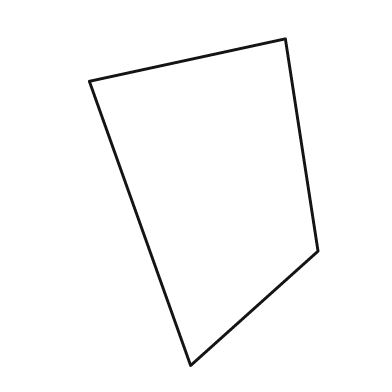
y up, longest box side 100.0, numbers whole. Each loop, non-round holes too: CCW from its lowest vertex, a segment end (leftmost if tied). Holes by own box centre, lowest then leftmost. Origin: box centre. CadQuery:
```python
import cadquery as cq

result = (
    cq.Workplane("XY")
    .moveTo(-4.0, -50.0)
    .lineTo(35.0, -15.0)
    .lineTo(25.0, 50.0)
    .lineTo(-35.0, 37.0)
    .close()
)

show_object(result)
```